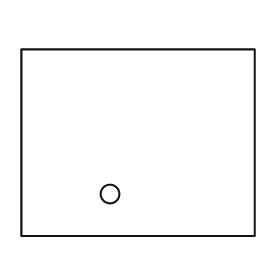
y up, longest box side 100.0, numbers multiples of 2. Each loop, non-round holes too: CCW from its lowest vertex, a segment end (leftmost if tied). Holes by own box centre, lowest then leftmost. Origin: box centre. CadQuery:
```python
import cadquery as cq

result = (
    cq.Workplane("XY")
    .moveTo(-50.0, -40.0)
    .lineTo(50.0, -40.0)
    .lineTo(50.0, 40.0)
    .lineTo(-50.0, 40.0)
    .close()
    .moveTo(-12.0, -22.0)
    .circle(4.0)
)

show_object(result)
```